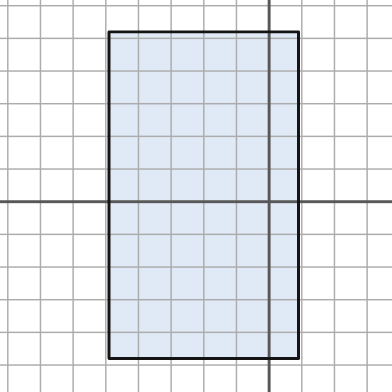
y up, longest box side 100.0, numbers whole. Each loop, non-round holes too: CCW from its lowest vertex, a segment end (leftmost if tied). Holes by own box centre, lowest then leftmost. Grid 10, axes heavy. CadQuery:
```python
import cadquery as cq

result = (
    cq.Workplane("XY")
    .moveTo(-49.0, -48.0)
    .lineTo(9.0, -48.0)
    .lineTo(9.0, 52.0)
    .lineTo(-49.0, 52.0)
    .close()
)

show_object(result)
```